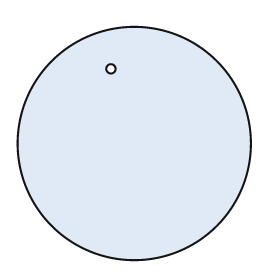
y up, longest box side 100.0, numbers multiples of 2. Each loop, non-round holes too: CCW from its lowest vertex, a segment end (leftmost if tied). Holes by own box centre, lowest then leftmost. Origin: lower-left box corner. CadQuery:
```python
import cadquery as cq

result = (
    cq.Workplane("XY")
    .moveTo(50.0, 50.0)
    .circle(50.0)
    .moveTo(40.0, 82.0)
    .circle(2.0)
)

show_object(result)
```